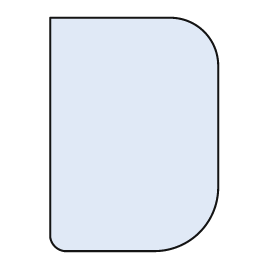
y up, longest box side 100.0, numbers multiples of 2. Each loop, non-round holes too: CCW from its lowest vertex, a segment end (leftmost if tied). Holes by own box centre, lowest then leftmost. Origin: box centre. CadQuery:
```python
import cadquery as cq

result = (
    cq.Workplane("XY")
    .moveTo(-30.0, -50.0)
    .lineTo(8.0, -50.0)
    .threePointArc((28.0, -42.0), (36.0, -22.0))
    .lineTo(36.0, 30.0)
    .threePointArc((30.0, 44.0), (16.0, 50.0))
    .lineTo(-36.0, 50.0)
    .lineTo(-36.0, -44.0)
    .threePointArc((-34.0, -48.0), (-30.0, -50.0))
    .close()
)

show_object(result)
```